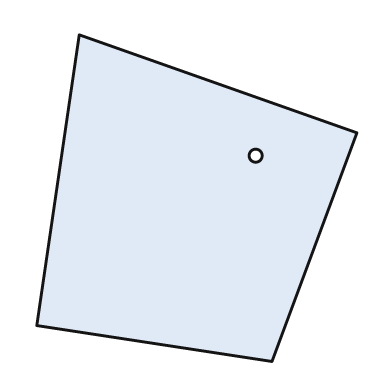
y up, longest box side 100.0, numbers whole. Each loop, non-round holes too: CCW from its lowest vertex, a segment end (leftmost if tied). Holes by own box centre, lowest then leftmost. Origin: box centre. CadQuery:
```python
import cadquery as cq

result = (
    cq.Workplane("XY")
    .moveTo(23.0, -50.0)
    .lineTo(49.0, 20.0)
    .lineTo(-36.0, 50.0)
    .lineTo(-49.0, -39.0)
    .close()
    .moveTo(18.0, 13.0)
    .circle(2.0)
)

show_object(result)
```